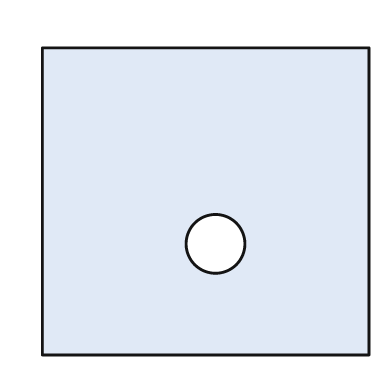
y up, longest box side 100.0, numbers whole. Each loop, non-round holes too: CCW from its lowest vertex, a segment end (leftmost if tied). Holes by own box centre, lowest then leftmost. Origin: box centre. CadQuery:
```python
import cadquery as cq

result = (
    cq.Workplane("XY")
    .moveTo(-50.0, -47.0)
    .lineTo(50.0, -47.0)
    .lineTo(50.0, 47.0)
    .lineTo(-50.0, 47.0)
    .close()
    .moveTo(3.0, -13.0)
    .circle(9.0)
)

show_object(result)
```